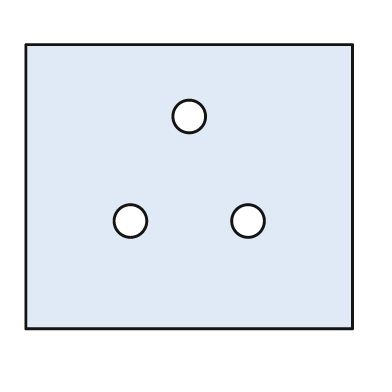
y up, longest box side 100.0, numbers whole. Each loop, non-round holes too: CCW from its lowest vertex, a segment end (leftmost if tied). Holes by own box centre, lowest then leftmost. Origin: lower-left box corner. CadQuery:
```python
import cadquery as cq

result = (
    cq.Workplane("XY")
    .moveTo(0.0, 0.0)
    .lineTo(100.0, 0.0)
    .lineTo(100.0, 87.0)
    .lineTo(0.0, 87.0)
    .close()
    .moveTo(32.0, 33.0)
    .circle(5.0)
    .moveTo(68.0, 33.0)
    .circle(5.0)
    .moveTo(50.0, 65.0)
    .circle(5.0)
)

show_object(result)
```